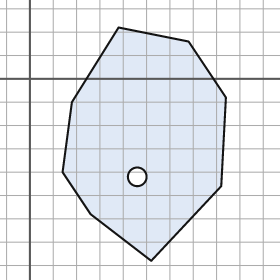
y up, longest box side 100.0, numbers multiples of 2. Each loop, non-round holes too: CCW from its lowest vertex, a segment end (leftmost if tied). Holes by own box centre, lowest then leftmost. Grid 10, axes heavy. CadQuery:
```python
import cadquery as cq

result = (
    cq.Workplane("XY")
    .moveTo(52.0, -78.0)
    .lineTo(82.0, -46.0)
    .lineTo(84.0, -8.0)
    .lineTo(68.0, 16.0)
    .lineTo(38.0, 22.0)
    .lineTo(18.0, -10.0)
    .lineTo(14.0, -40.0)
    .lineTo(26.0, -58.0)
    .close()
    .moveTo(46.0, -42.0)
    .circle(4.0)
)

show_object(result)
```